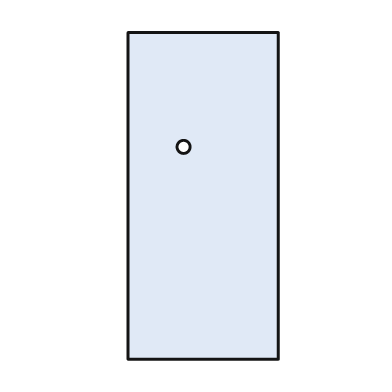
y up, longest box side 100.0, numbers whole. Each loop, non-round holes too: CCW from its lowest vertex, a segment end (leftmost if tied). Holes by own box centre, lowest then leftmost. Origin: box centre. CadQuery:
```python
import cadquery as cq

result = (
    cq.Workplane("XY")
    .moveTo(-23.0, -50.0)
    .lineTo(23.0, -50.0)
    .lineTo(23.0, 50.0)
    .lineTo(-23.0, 50.0)
    .close()
    .moveTo(-6.0, 15.0)
    .circle(2.0)
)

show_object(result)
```